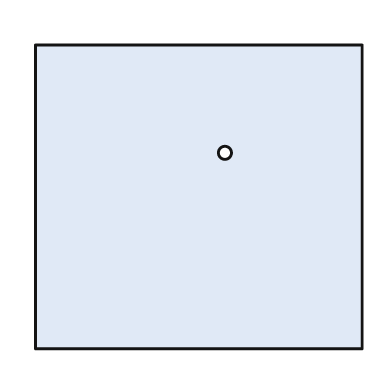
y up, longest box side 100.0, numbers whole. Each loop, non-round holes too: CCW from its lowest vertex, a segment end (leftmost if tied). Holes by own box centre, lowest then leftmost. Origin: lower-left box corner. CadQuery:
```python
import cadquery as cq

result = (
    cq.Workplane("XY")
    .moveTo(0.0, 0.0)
    .lineTo(100.0, 0.0)
    .lineTo(100.0, 93.0)
    .lineTo(0.0, 93.0)
    .close()
    .moveTo(58.0, 60.0)
    .circle(2.0)
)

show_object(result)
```